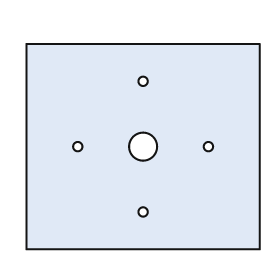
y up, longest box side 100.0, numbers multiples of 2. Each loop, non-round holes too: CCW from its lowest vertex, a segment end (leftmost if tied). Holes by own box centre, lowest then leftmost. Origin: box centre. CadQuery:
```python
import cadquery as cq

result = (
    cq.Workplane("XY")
    .moveTo(-50.0, -44.0)
    .lineTo(50.0, -44.0)
    .lineTo(50.0, 44.0)
    .lineTo(-50.0, 44.0)
    .close()
    .moveTo(0.0, -28.0)
    .circle(2.0)
    .moveTo(-28.0, 0.0)
    .circle(2.0)
    .moveTo(0.0, 0.0)
    .circle(6.0)
    .moveTo(28.0, 0.0)
    .circle(2.0)
    .moveTo(0.0, 28.0)
    .circle(2.0)
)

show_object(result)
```